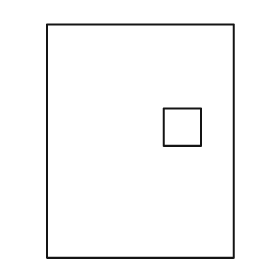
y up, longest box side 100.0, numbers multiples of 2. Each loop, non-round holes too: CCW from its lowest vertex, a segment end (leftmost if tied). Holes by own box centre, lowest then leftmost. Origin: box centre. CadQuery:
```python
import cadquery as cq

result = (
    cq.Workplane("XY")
    .moveTo(-40.0, -50.0)
    .lineTo(40.0, -50.0)
    .lineTo(40.0, 50.0)
    .lineTo(-40.0, 50.0)
    .close()
    .moveTo(10.0, -2.0)
    .lineTo(26.0, -2.0)
    .lineTo(26.0, 14.0)
    .lineTo(10.0, 14.0)
    .close()
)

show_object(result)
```